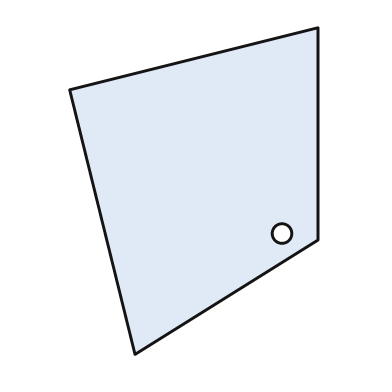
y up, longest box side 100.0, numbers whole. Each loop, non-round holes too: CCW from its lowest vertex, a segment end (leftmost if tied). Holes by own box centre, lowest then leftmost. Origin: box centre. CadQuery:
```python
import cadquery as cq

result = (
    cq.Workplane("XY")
    .moveTo(-18.0, -50.0)
    .lineTo(38.0, -15.0)
    .lineTo(38.0, 50.0)
    .lineTo(-38.0, 31.0)
    .close()
    .moveTo(27.0, -13.0)
    .circle(3.0)
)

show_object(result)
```